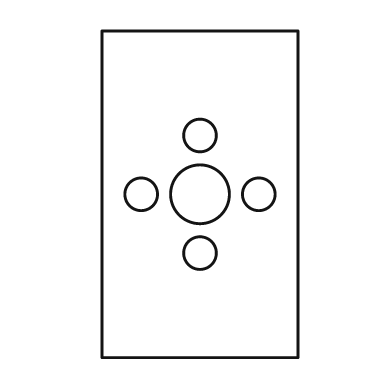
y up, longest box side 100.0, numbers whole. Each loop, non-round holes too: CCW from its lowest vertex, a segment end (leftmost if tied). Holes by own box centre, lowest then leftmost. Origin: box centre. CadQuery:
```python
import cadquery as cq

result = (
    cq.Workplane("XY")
    .moveTo(-30.0, -50.0)
    .lineTo(30.0, -50.0)
    .lineTo(30.0, 50.0)
    .lineTo(-30.0, 50.0)
    .close()
    .moveTo(0.0, -18.0)
    .circle(5.0)
    .moveTo(-18.0, 0.0)
    .circle(5.0)
    .moveTo(0.0, 0.0)
    .circle(9.0)
    .moveTo(18.0, 0.0)
    .circle(5.0)
    .moveTo(0.0, 18.0)
    .circle(5.0)
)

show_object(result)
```